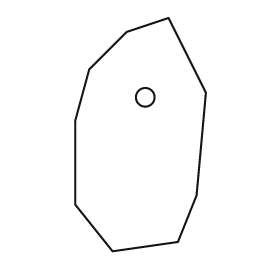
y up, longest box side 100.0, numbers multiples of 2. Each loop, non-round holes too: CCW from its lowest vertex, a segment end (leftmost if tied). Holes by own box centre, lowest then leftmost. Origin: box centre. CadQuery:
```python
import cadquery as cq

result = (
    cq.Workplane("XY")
    .moveTo(-12.0, -50.0)
    .lineTo(16.0, -46.0)
    .lineTo(24.0, -26.0)
    .lineTo(28.0, 18.0)
    .lineTo(12.0, 50.0)
    .lineTo(-6.0, 44.0)
    .lineTo(-22.0, 28.0)
    .lineTo(-28.0, 6.0)
    .lineTo(-28.0, -30.0)
    .close()
    .moveTo(2.0, 16.0)
    .circle(4.0)
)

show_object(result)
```